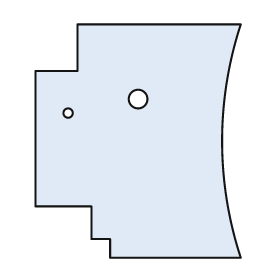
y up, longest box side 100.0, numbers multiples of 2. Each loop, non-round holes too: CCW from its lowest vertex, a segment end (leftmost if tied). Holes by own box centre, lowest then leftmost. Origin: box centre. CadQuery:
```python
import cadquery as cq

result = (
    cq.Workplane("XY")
    .moveTo(-12.0, -50.0)
    .lineTo(44.0, -50.0)
    .threePointArc((36.0, 0.0), (44.0, 50.0))
    .lineTo(-26.0, 50.0)
    .lineTo(-26.0, 30.0)
    .lineTo(-44.0, 30.0)
    .lineTo(-44.0, -28.0)
    .lineTo(-20.0, -28.0)
    .lineTo(-20.0, -42.0)
    .lineTo(-12.0, -42.0)
    .close()
    .moveTo(-30.0, 12.0)
    .circle(2.0)
    .moveTo(0.0, 18.0)
    .circle(4.0)
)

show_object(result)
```